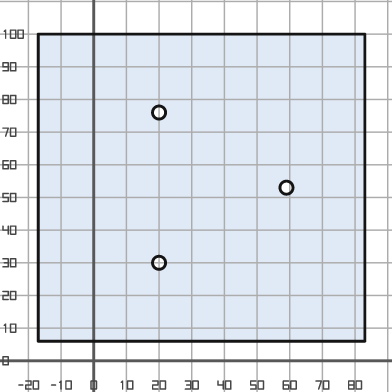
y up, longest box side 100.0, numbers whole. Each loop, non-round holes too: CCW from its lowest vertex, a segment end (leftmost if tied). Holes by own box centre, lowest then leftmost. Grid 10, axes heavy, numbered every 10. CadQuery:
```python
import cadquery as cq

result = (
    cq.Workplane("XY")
    .moveTo(-17.0, 6.0)
    .lineTo(83.0, 6.0)
    .lineTo(83.0, 100.0)
    .lineTo(-17.0, 100.0)
    .close()
    .moveTo(20.0, 30.0)
    .circle(2.0)
    .moveTo(59.0, 53.0)
    .circle(2.0)
    .moveTo(20.0, 76.0)
    .circle(2.0)
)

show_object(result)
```